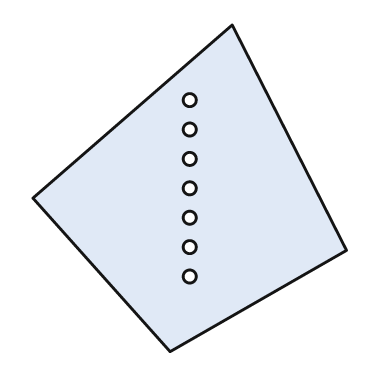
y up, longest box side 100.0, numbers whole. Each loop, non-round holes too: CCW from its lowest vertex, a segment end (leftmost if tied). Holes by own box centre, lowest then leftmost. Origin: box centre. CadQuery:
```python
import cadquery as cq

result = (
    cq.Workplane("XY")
    .moveTo(-6.0, -50.0)
    .lineTo(48.0, -19.0)
    .lineTo(13.0, 50.0)
    .lineTo(-48.0, -3.0)
    .close()
    .moveTo(0.0, -27.0)
    .circle(2.0)
    .moveTo(0.0, -18.0)
    .circle(2.0)
    .moveTo(0.0, -9.0)
    .circle(2.0)
    .moveTo(0.0, 0.0)
    .circle(2.0)
    .moveTo(0.0, 9.0)
    .circle(2.0)
    .moveTo(0.0, 18.0)
    .circle(2.0)
    .moveTo(0.0, 27.0)
    .circle(2.0)
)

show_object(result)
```